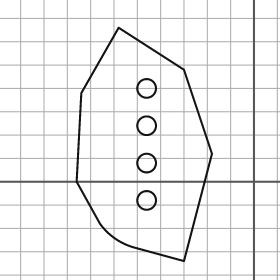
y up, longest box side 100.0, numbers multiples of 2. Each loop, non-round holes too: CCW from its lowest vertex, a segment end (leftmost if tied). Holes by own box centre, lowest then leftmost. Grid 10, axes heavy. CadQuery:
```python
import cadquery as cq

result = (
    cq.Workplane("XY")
    .moveTo(-30.0, -34.0)
    .lineTo(-18.0, 12.0)
    .lineTo(-30.0, 48.0)
    .lineTo(-58.0, 66.0)
    .lineTo(-74.0, 38.0)
    .lineTo(-76.0, 0.0)
    .lineTo(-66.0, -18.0)
    .threePointArc((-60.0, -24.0), (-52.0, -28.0))
    .close()
    .moveTo(-46.0, -8.0)
    .circle(4.0)
    .moveTo(-46.0, 8.0)
    .circle(4.0)
    .moveTo(-46.0, 24.0)
    .circle(4.0)
    .moveTo(-46.0, 40.0)
    .circle(4.0)
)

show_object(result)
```